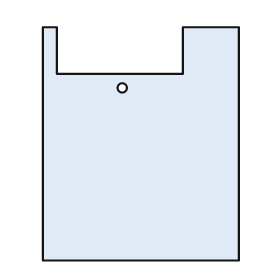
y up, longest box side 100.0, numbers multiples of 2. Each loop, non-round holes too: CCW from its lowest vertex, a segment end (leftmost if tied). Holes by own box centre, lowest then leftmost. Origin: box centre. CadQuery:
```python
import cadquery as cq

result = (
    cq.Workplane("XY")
    .moveTo(-42.0, -50.0)
    .lineTo(42.0, -50.0)
    .lineTo(42.0, 50.0)
    .lineTo(18.0, 50.0)
    .lineTo(18.0, 30.0)
    .lineTo(-36.0, 30.0)
    .lineTo(-36.0, 50.0)
    .lineTo(-42.0, 50.0)
    .close()
    .moveTo(-8.0, 24.0)
    .circle(2.0)
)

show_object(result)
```